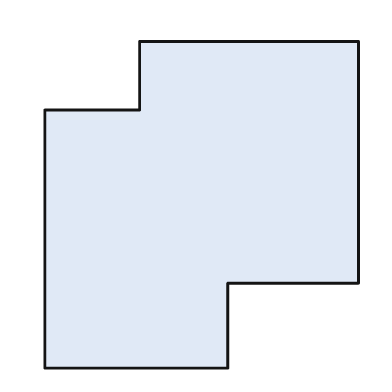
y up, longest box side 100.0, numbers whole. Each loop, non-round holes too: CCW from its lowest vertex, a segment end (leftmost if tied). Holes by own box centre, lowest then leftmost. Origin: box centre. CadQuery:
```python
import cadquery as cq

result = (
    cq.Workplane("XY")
    .moveTo(-48.0, -50.0)
    .lineTo(8.0, -50.0)
    .lineTo(8.0, -24.0)
    .lineTo(48.0, -24.0)
    .lineTo(48.0, 50.0)
    .lineTo(-19.0, 50.0)
    .lineTo(-19.0, 29.0)
    .lineTo(-48.0, 29.0)
    .close()
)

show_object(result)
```